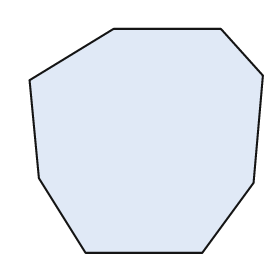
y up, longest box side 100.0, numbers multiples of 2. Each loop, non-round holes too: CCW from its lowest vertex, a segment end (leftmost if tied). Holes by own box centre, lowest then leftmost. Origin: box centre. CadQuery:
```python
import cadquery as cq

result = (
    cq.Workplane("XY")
    .moveTo(-26.0, -48.0)
    .lineTo(24.0, -48.0)
    .lineTo(46.0, -18.0)
    .lineTo(50.0, 28.0)
    .lineTo(32.0, 48.0)
    .lineTo(-14.0, 48.0)
    .lineTo(-50.0, 26.0)
    .lineTo(-46.0, -16.0)
    .close()
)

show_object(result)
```